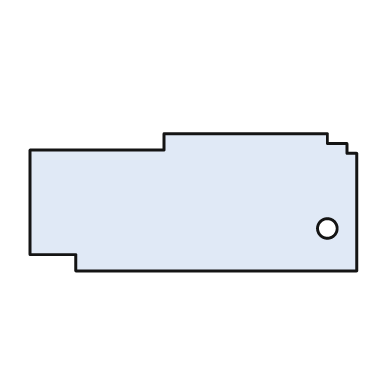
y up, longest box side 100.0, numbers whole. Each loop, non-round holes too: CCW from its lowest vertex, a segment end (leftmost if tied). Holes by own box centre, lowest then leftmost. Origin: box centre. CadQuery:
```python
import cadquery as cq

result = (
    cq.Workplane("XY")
    .moveTo(-36.0, -21.0)
    .lineTo(50.0, -21.0)
    .lineTo(50.0, 15.0)
    .lineTo(47.0, 15.0)
    .lineTo(47.0, 18.0)
    .lineTo(41.0, 18.0)
    .lineTo(41.0, 21.0)
    .lineTo(-9.0, 21.0)
    .lineTo(-9.0, 16.0)
    .lineTo(-50.0, 16.0)
    .lineTo(-50.0, -16.0)
    .lineTo(-36.0, -16.0)
    .close()
    .moveTo(41.0, -8.0)
    .circle(3.0)
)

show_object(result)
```